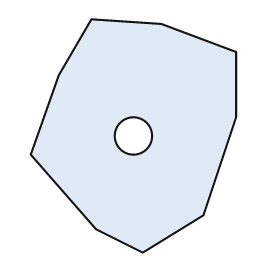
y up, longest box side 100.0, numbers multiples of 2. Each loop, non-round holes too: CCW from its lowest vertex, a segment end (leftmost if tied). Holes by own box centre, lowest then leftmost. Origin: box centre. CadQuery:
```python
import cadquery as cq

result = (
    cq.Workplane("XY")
    .moveTo(4.0, -50.0)
    .lineTo(30.0, -34.0)
    .lineTo(44.0, 8.0)
    .lineTo(44.0, 36.0)
    .lineTo(12.0, 48.0)
    .lineTo(-18.0, 50.0)
    .lineTo(-32.0, 26.0)
    .lineTo(-44.0, -8.0)
    .lineTo(-16.0, -40.0)
    .close()
    .moveTo(0.0, 0.0)
    .circle(8.0)
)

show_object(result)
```